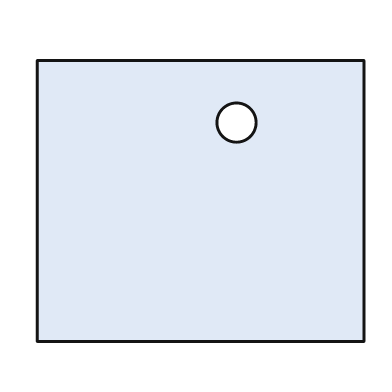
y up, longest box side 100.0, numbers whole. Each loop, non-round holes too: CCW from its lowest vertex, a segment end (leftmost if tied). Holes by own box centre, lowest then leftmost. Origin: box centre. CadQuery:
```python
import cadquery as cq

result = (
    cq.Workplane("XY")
    .moveTo(-50.0, -43.0)
    .lineTo(50.0, -43.0)
    .lineTo(50.0, 43.0)
    .lineTo(-50.0, 43.0)
    .close()
    .moveTo(11.0, 24.0)
    .circle(6.0)
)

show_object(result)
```